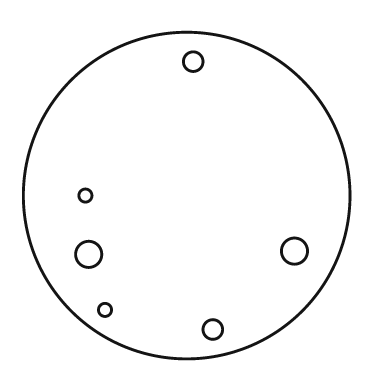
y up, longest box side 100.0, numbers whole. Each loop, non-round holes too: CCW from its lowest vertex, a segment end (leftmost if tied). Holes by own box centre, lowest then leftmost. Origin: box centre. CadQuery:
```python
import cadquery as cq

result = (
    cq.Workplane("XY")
    .moveTo(0.0, 0.0)
    .circle(50.0)
    .moveTo(8.0, -41.0)
    .circle(3.0)
    .moveTo(-25.0, -35.0)
    .circle(2.0)
    .moveTo(-30.0, -18.0)
    .circle(4.0)
    .moveTo(33.0, -17.0)
    .circle(4.0)
    .moveTo(-31.0, 0.0)
    .circle(2.0)
    .moveTo(2.0, 41.0)
    .circle(3.0)
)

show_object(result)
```